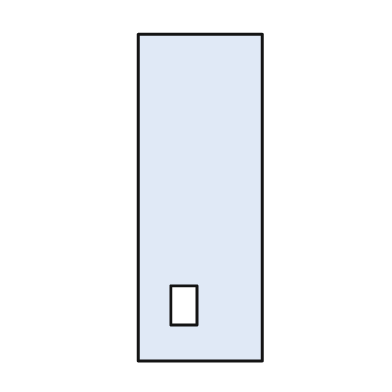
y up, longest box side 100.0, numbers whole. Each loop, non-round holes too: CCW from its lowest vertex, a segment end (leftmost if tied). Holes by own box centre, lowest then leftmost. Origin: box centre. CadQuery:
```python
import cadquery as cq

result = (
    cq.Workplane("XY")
    .moveTo(-19.0, -50.0)
    .lineTo(19.0, -50.0)
    .lineTo(19.0, 50.0)
    .lineTo(-19.0, 50.0)
    .close()
    .moveTo(-9.0, -39.0)
    .lineTo(-1.0, -39.0)
    .lineTo(-1.0, -27.0)
    .lineTo(-9.0, -27.0)
    .close()
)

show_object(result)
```